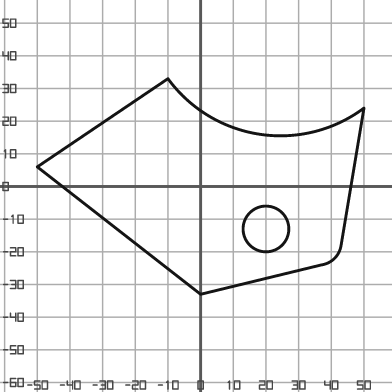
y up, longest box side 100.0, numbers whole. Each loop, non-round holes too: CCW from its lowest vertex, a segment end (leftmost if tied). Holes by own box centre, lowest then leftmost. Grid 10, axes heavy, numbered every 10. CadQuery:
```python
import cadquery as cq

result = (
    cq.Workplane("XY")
    .moveTo(0.0, -33.0)
    .lineTo(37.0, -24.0)
    .threePointArc((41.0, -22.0), (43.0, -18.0))
    .lineTo(50.0, 24.0)
    .threePointArc((18.0, 16.0), (-10.0, 33.0))
    .lineTo(-50.0, 6.0)
    .close()
    .moveTo(20.0, -13.0)
    .circle(7.0)
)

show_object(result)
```